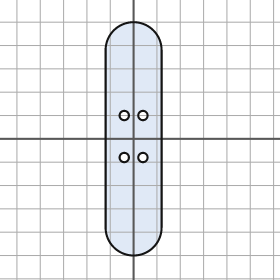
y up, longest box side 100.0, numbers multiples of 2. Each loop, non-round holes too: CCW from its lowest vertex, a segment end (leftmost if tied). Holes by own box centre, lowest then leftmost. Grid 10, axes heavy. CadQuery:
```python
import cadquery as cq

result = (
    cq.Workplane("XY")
    .moveTo(-12.0, -38.0)
    .threePointArc((0.0, -50.0), (12.0, -38.0))
    .lineTo(12.0, 38.0)
    .threePointArc((0.0, 50.0), (-12.0, 38.0))
    .close()
    .moveTo(-4.0, -8.0)
    .circle(2.0)
    .moveTo(4.0, -8.0)
    .circle(2.0)
    .moveTo(-4.0, 10.0)
    .circle(2.0)
    .moveTo(4.0, 10.0)
    .circle(2.0)
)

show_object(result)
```